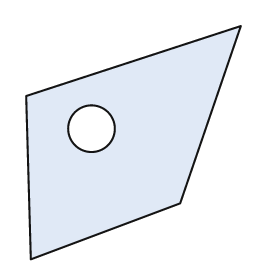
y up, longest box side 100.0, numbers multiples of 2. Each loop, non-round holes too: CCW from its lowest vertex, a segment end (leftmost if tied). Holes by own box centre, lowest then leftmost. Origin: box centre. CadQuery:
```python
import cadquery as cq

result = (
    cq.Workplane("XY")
    .moveTo(-44.0, -50.0)
    .lineTo(20.0, -26.0)
    .lineTo(46.0, 50.0)
    .lineTo(-46.0, 20.0)
    .close()
    .moveTo(-18.0, 6.0)
    .circle(10.0)
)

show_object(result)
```